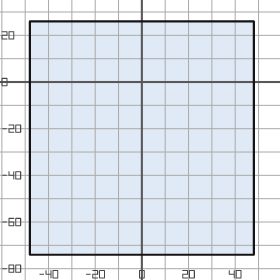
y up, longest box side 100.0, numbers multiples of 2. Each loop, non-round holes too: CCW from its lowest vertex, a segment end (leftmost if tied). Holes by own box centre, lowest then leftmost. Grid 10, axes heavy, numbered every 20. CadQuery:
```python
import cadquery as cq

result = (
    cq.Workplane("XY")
    .moveTo(-48.0, -74.0)
    .lineTo(48.0, -74.0)
    .lineTo(48.0, 26.0)
    .lineTo(-48.0, 26.0)
    .close()
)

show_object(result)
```